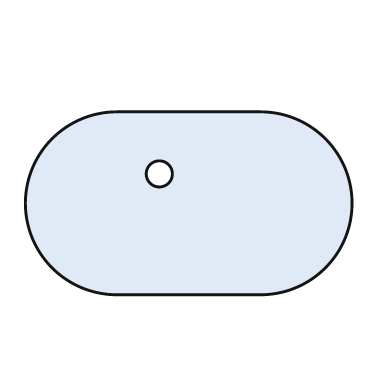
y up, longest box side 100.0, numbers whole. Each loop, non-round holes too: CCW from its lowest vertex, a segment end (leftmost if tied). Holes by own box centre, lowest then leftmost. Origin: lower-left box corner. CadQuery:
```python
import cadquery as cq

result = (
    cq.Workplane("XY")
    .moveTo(28.0, 0.0)
    .lineTo(72.0, 0.0)
    .threePointArc((100.0, 28.0), (72.0, 56.0))
    .lineTo(28.0, 56.0)
    .threePointArc((0.0, 28.0), (28.0, 0.0))
    .close()
    .moveTo(41.0, 37.0)
    .circle(4.0)
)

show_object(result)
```